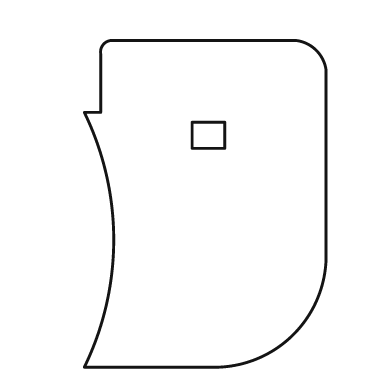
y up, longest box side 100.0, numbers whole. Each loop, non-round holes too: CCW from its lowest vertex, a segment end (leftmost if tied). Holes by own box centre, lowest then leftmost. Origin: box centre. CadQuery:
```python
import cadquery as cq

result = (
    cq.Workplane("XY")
    .moveTo(-37.0, -50.0)
    .lineTo(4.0, -50.0)
    .threePointArc((27.0, -40.0), (37.0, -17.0))
    .lineTo(37.0, 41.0)
    .threePointArc((34.0, 47.0), (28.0, 50.0))
    .lineTo(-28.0, 50.0)
    .threePointArc((-31.0, 49.0), (-32.0, 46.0))
    .lineTo(-32.0, 28.0)
    .lineTo(-37.0, 28.0)
    .threePointArc((-28.0, -11.0), (-37.0, -50.0))
    .close()
    .moveTo(-4.0, 17.0)
    .lineTo(6.0, 17.0)
    .lineTo(6.0, 25.0)
    .lineTo(-4.0, 25.0)
    .close()
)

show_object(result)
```